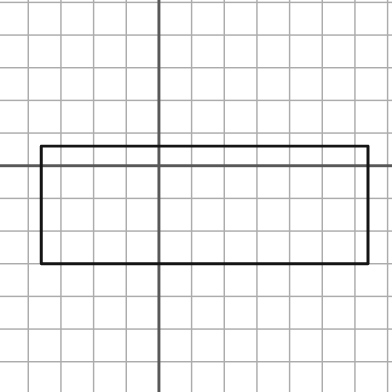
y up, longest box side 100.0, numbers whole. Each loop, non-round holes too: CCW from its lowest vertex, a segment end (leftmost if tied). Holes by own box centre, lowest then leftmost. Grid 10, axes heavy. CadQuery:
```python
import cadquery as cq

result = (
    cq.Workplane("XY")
    .moveTo(-36.0, -30.0)
    .lineTo(64.0, -30.0)
    .lineTo(64.0, 6.0)
    .lineTo(-36.0, 6.0)
    .close()
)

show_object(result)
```